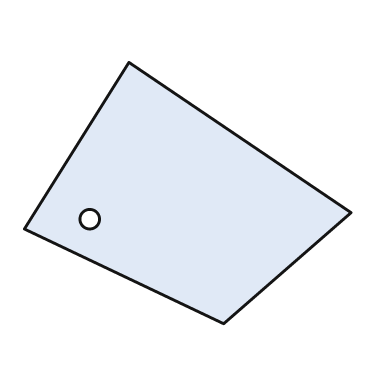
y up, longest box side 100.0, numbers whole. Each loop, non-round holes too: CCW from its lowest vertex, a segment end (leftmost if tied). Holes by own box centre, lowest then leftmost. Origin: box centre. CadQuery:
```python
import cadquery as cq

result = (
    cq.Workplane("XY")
    .moveTo(11.0, -40.0)
    .lineTo(50.0, -6.0)
    .lineTo(-18.0, 40.0)
    .lineTo(-50.0, -11.0)
    .close()
    .moveTo(-30.0, -8.0)
    .circle(3.0)
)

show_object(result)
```